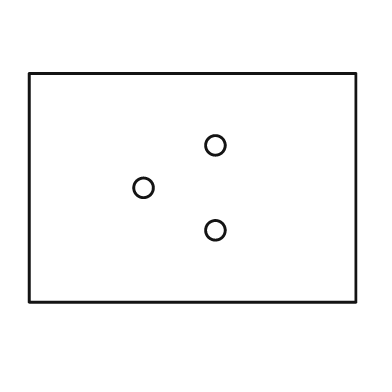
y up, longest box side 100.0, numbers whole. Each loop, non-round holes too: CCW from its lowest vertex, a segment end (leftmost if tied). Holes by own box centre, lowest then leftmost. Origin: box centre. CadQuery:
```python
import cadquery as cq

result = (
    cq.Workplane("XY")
    .moveTo(-50.0, -35.0)
    .lineTo(50.0, -35.0)
    .lineTo(50.0, 35.0)
    .lineTo(-50.0, 35.0)
    .close()
    .moveTo(7.0, -13.0)
    .circle(3.0)
    .moveTo(-15.0, 0.0)
    .circle(3.0)
    .moveTo(7.0, 13.0)
    .circle(3.0)
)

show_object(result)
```